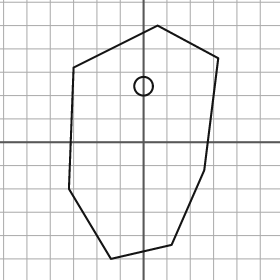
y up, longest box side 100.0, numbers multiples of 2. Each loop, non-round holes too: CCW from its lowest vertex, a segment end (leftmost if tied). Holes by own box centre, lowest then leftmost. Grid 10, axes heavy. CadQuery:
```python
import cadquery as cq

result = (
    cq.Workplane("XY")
    .moveTo(-14.0, -50.0)
    .lineTo(12.0, -44.0)
    .lineTo(26.0, -12.0)
    .lineTo(32.0, 36.0)
    .lineTo(6.0, 50.0)
    .lineTo(-30.0, 32.0)
    .lineTo(-32.0, -20.0)
    .close()
    .moveTo(0.0, 24.0)
    .circle(4.0)
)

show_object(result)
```